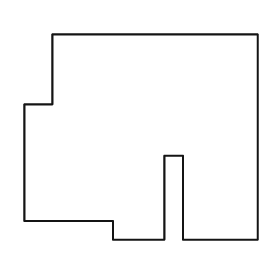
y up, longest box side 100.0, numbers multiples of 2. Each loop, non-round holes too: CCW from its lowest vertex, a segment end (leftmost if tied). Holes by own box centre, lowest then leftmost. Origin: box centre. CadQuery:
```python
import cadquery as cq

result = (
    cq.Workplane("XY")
    .moveTo(-12.0, -44.0)
    .lineTo(10.0, -44.0)
    .lineTo(10.0, -8.0)
    .lineTo(18.0, -8.0)
    .lineTo(18.0, -44.0)
    .lineTo(50.0, -44.0)
    .lineTo(50.0, 44.0)
    .lineTo(-38.0, 44.0)
    .lineTo(-38.0, 14.0)
    .lineTo(-50.0, 14.0)
    .lineTo(-50.0, -36.0)
    .lineTo(-12.0, -36.0)
    .close()
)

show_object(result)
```